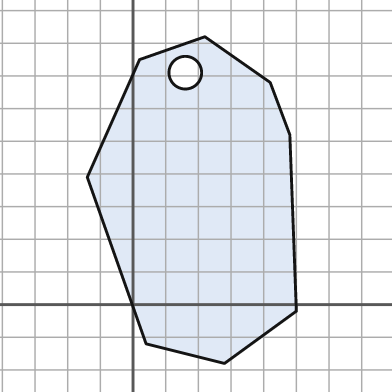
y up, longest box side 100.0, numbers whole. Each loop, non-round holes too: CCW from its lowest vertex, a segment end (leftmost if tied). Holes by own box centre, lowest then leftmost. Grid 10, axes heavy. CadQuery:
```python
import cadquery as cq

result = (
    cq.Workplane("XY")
    .moveTo(28.0, -18.0)
    .lineTo(50.0, -2.0)
    .lineTo(48.0, 52.0)
    .lineTo(42.0, 68.0)
    .lineTo(22.0, 82.0)
    .lineTo(2.0, 75.0)
    .lineTo(-14.0, 39.0)
    .lineTo(4.0, -12.0)
    .close()
    .moveTo(16.0, 71.0)
    .circle(5.0)
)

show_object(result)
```